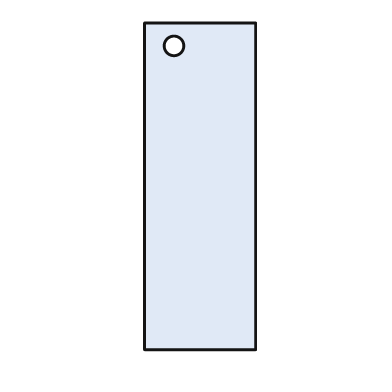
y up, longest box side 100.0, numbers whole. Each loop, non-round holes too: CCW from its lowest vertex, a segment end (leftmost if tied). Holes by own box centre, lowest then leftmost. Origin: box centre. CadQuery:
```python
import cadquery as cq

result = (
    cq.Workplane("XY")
    .moveTo(-17.0, -50.0)
    .lineTo(17.0, -50.0)
    .lineTo(17.0, 50.0)
    .lineTo(-17.0, 50.0)
    .close()
    .moveTo(-8.0, 43.0)
    .circle(3.0)
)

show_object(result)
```